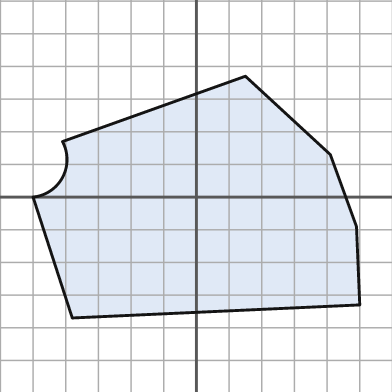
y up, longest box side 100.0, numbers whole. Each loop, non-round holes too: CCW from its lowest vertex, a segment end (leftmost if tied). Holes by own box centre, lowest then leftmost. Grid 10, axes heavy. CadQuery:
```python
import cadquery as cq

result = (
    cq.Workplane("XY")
    .moveTo(-38.0, -37.0)
    .lineTo(50.0, -33.0)
    .lineTo(49.0, -9.0)
    .lineTo(41.0, 13.0)
    .lineTo(15.0, 37.0)
    .lineTo(-41.0, 17.0)
    .threePointArc((-41.0, 6.0), (-50.0, 0.0))
    .close()
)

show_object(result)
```